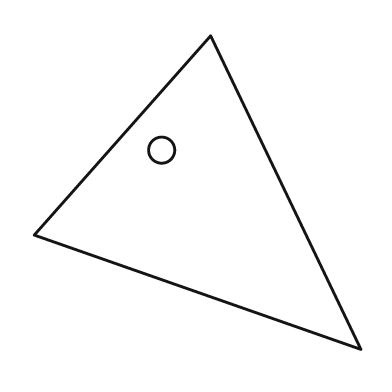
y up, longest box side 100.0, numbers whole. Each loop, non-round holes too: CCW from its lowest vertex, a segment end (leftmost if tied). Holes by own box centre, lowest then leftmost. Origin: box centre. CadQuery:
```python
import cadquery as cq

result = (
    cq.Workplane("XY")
    .moveTo(50.0, -48.0)
    .lineTo(4.0, 48.0)
    .lineTo(-50.0, -13.0)
    .close()
    .moveTo(-11.0, 13.0)
    .circle(4.0)
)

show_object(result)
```